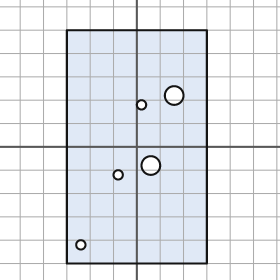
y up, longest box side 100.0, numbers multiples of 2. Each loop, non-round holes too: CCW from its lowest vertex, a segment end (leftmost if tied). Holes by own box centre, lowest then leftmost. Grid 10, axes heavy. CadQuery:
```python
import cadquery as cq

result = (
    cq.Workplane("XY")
    .moveTo(-30.0, -50.0)
    .lineTo(30.0, -50.0)
    .lineTo(30.0, 50.0)
    .lineTo(-30.0, 50.0)
    .close()
    .moveTo(-24.0, -42.0)
    .circle(2.0)
    .moveTo(-8.0, -12.0)
    .circle(2.0)
    .moveTo(6.0, -8.0)
    .circle(4.0)
    .moveTo(2.0, 18.0)
    .circle(2.0)
    .moveTo(16.0, 22.0)
    .circle(4.0)
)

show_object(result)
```